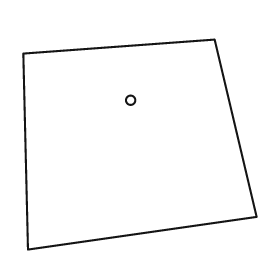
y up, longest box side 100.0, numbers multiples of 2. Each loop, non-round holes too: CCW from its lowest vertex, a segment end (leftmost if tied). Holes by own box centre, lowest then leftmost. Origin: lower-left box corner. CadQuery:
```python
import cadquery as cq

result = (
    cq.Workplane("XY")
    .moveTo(2.0, 0.0)
    .lineTo(100.0, 14.0)
    .lineTo(82.0, 90.0)
    .lineTo(0.0, 84.0)
    .close()
    .moveTo(46.0, 64.0)
    .circle(2.0)
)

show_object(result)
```